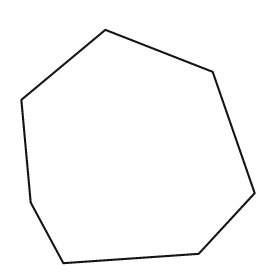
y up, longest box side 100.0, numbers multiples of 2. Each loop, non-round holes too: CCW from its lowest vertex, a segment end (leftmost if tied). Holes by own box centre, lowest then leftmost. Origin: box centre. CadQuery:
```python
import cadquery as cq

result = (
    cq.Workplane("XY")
    .moveTo(-32.0, -50.0)
    .lineTo(26.0, -46.0)
    .lineTo(50.0, -20.0)
    .lineTo(32.0, 32.0)
    .lineTo(-14.0, 50.0)
    .lineTo(-50.0, 20.0)
    .lineTo(-46.0, -24.0)
    .close()
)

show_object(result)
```